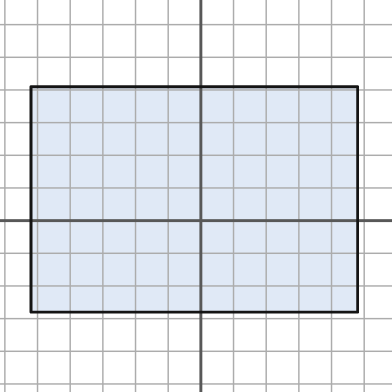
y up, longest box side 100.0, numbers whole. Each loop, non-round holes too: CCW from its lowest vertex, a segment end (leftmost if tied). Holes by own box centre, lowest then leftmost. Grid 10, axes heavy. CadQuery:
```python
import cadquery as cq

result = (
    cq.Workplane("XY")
    .moveTo(-52.0, -28.0)
    .lineTo(48.0, -28.0)
    .lineTo(48.0, 41.0)
    .lineTo(-52.0, 41.0)
    .close()
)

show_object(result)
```